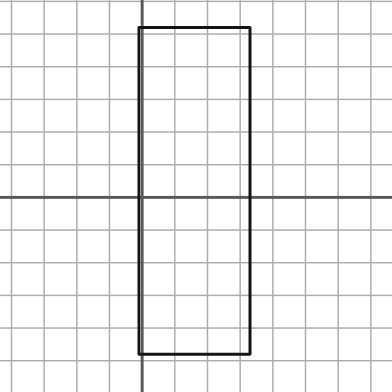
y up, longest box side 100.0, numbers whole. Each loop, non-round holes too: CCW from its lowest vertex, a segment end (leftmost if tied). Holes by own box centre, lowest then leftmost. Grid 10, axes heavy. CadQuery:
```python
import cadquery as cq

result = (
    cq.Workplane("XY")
    .moveTo(-1.0, -48.0)
    .lineTo(33.0, -48.0)
    .lineTo(33.0, 52.0)
    .lineTo(-1.0, 52.0)
    .close()
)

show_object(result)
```